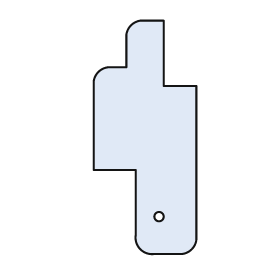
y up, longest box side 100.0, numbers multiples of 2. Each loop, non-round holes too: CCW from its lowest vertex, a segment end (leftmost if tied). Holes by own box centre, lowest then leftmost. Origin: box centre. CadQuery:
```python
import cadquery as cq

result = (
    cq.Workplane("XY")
    .moveTo(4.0, -50.0)
    .lineTo(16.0, -50.0)
    .threePointArc((20.0, -48.0), (22.0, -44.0))
    .lineTo(22.0, 22.0)
    .lineTo(8.0, 22.0)
    .lineTo(8.0, 50.0)
    .lineTo(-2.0, 50.0)
    .threePointArc((-6.0, 48.0), (-8.0, 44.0))
    .lineTo(-8.0, 30.0)
    .lineTo(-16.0, 30.0)
    .threePointArc((-20.0, 28.0), (-22.0, 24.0))
    .lineTo(-22.0, -14.0)
    .lineTo(-4.0, -14.0)
    .lineTo(-4.0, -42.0)
    .threePointArc((-2.0, -48.0), (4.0, -50.0))
    .close()
    .moveTo(6.0, -34.0)
    .circle(2.0)
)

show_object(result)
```